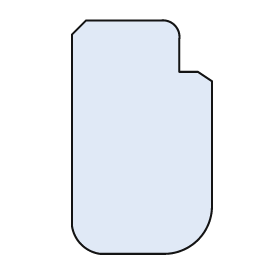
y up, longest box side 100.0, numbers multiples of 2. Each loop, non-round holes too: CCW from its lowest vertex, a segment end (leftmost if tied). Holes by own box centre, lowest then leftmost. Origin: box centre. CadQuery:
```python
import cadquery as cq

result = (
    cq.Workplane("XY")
    .moveTo(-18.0, -50.0)
    .lineTo(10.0, -50.0)
    .threePointArc((24.0, -44.0), (30.0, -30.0))
    .lineTo(30.0, 24.0)
    .lineTo(24.0, 28.0)
    .lineTo(16.0, 28.0)
    .lineTo(16.0, 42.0)
    .threePointArc((14.0, 48.0), (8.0, 50.0))
    .lineTo(-24.0, 50.0)
    .lineTo(-30.0, 44.0)
    .lineTo(-30.0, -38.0)
    .threePointArc((-26.0, -46.0), (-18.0, -50.0))
    .close()
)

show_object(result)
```